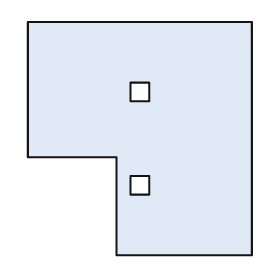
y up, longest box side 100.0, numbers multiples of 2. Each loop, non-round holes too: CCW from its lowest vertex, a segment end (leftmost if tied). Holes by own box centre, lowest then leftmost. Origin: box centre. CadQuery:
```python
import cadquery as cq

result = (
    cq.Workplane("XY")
    .moveTo(-10.0, -50.0)
    .lineTo(48.0, -50.0)
    .lineTo(48.0, 50.0)
    .lineTo(-48.0, 50.0)
    .lineTo(-48.0, -8.0)
    .lineTo(-10.0, -8.0)
    .close()
    .moveTo(-4.0, -24.0)
    .lineTo(4.0, -24.0)
    .lineTo(4.0, -16.0)
    .lineTo(-4.0, -16.0)
    .close()
    .moveTo(-4.0, 16.0)
    .lineTo(4.0, 16.0)
    .lineTo(4.0, 24.0)
    .lineTo(-4.0, 24.0)
    .close()
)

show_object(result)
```